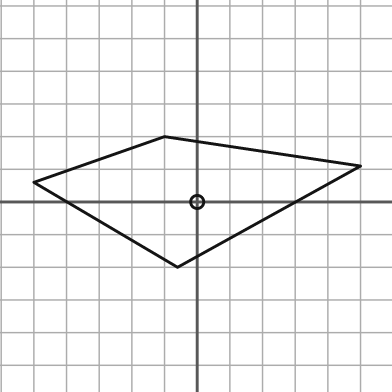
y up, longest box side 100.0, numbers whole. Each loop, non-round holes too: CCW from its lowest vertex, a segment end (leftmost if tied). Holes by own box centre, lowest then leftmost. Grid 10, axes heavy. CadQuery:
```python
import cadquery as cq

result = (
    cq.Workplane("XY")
    .moveTo(-6.0, -20.0)
    .lineTo(50.0, 11.0)
    .lineTo(-10.0, 20.0)
    .lineTo(-50.0, 6.0)
    .close()
    .moveTo(0.0, 0.0)
    .circle(2.0)
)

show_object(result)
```